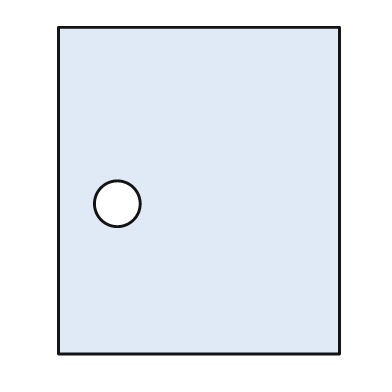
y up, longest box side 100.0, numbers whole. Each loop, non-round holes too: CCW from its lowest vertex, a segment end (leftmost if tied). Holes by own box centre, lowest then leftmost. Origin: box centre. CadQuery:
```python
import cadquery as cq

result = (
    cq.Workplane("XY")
    .moveTo(-43.0, -50.0)
    .lineTo(43.0, -50.0)
    .lineTo(43.0, 50.0)
    .lineTo(-43.0, 50.0)
    .close()
    .moveTo(-25.0, -4.0)
    .circle(7.0)
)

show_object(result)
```